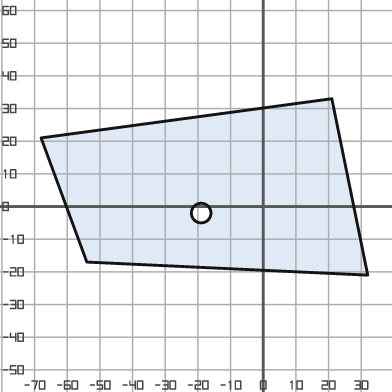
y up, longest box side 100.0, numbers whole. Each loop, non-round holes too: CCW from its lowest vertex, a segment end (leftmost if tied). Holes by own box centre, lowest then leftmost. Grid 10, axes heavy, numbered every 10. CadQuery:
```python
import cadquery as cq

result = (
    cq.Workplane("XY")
    .moveTo(32.0, -21.0)
    .lineTo(21.0, 33.0)
    .lineTo(-68.0, 21.0)
    .lineTo(-54.0, -17.0)
    .close()
    .moveTo(-19.0, -2.0)
    .circle(3.0)
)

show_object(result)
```